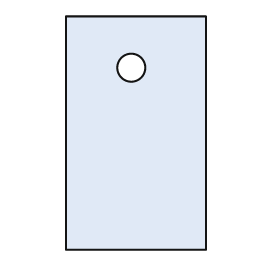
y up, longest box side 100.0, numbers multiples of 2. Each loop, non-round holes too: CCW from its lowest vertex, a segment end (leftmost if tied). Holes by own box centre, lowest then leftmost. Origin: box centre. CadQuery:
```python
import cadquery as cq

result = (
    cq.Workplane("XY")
    .moveTo(-30.0, -50.0)
    .lineTo(30.0, -50.0)
    .lineTo(30.0, 50.0)
    .lineTo(-30.0, 50.0)
    .close()
    .moveTo(-2.0, 28.0)
    .circle(6.0)
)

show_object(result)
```